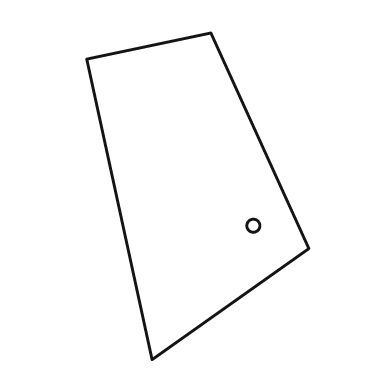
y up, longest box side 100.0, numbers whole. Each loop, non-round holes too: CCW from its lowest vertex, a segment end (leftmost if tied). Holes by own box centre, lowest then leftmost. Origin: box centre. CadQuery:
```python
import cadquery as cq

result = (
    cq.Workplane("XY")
    .moveTo(-14.0, -50.0)
    .lineTo(34.0, -16.0)
    .lineTo(4.0, 50.0)
    .lineTo(-34.0, 42.0)
    .close()
    .moveTo(17.0, -9.0)
    .circle(2.0)
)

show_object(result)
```